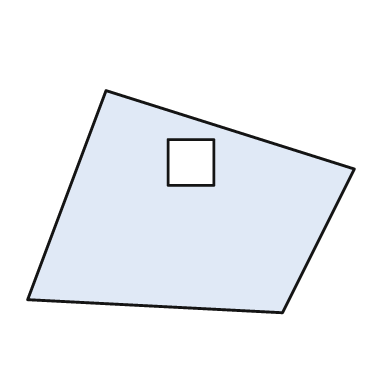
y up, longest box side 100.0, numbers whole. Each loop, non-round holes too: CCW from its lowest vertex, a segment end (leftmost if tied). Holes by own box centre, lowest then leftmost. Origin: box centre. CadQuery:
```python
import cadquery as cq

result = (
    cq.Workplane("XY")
    .moveTo(28.0, -34.0)
    .lineTo(50.0, 10.0)
    .lineTo(-26.0, 34.0)
    .lineTo(-50.0, -30.0)
    .close()
    .moveTo(-7.0, 5.0)
    .lineTo(7.0, 5.0)
    .lineTo(7.0, 19.0)
    .lineTo(-7.0, 19.0)
    .close()
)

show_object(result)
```